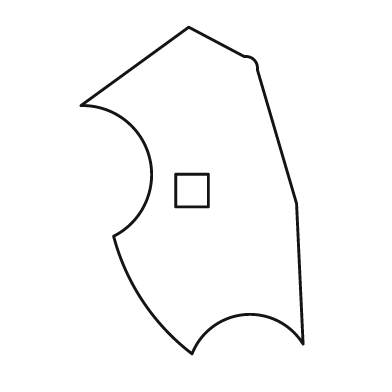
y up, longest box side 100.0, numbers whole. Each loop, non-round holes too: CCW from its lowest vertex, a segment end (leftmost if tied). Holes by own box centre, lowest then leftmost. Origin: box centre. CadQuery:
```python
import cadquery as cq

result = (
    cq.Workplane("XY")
    .moveTo(0.0, -50.0)
    .threePointArc((16.0, -38.0), (34.0, -47.0))
    .lineTo(32.0, -4.0)
    .lineTo(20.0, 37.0)
    .threePointArc((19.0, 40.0), (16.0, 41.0))
    .lineTo(-1.0, 50.0)
    .lineTo(-34.0, 26.0)
    .threePointArc((-13.0, 10.0), (-24.0, -14.0))
    .threePointArc((-15.0, -34.0), (0.0, -50.0))
    .close()
    .moveTo(-5.0, -5.0)
    .lineTo(5.0, -5.0)
    .lineTo(5.0, 5.0)
    .lineTo(-5.0, 5.0)
    .close()
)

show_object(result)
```